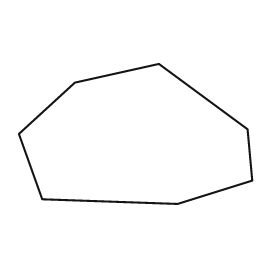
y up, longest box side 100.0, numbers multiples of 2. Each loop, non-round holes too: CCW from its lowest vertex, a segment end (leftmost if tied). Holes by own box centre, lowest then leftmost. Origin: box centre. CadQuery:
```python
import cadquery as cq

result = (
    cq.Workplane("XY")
    .moveTo(18.0, -30.0)
    .lineTo(50.0, -20.0)
    .lineTo(48.0, 2.0)
    .lineTo(10.0, 30.0)
    .lineTo(-26.0, 22.0)
    .lineTo(-50.0, 0.0)
    .lineTo(-40.0, -28.0)
    .close()
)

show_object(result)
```